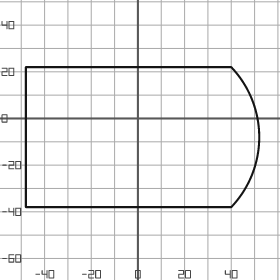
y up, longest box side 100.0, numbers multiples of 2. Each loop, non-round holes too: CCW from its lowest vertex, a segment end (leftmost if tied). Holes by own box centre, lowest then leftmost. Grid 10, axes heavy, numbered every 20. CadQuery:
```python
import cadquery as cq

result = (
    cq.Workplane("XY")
    .moveTo(-48.0, -38.0)
    .lineTo(40.0, -38.0)
    .threePointArc((52.0, -8.0), (40.0, 22.0))
    .lineTo(-48.0, 22.0)
    .close()
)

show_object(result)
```